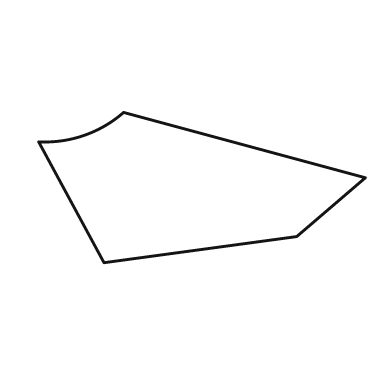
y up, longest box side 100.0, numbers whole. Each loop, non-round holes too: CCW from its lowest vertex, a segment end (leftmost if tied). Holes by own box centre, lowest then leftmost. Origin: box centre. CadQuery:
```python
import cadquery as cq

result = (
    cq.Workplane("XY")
    .moveTo(-30.0, -23.0)
    .lineTo(29.0, -15.0)
    .lineTo(50.0, 3.0)
    .lineTo(-24.0, 23.0)
    .threePointArc((-36.0, 16.0), (-50.0, 14.0))
    .close()
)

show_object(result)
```